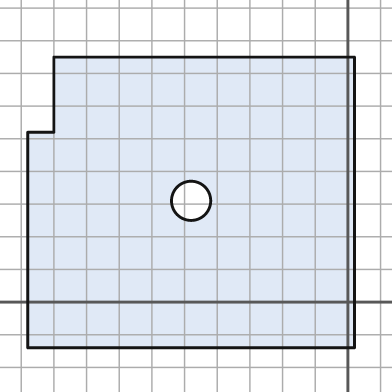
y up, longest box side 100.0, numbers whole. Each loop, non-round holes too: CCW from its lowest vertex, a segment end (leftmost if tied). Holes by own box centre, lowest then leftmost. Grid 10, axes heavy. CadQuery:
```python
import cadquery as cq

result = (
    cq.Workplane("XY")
    .moveTo(-98.0, -14.0)
    .lineTo(2.0, -14.0)
    .lineTo(2.0, 75.0)
    .lineTo(-90.0, 75.0)
    .lineTo(-90.0, 52.0)
    .lineTo(-98.0, 52.0)
    .close()
    .moveTo(-48.0, 31.0)
    .circle(6.0)
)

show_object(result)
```